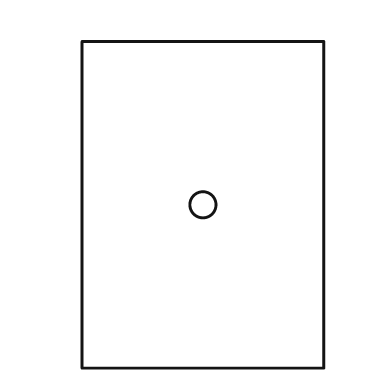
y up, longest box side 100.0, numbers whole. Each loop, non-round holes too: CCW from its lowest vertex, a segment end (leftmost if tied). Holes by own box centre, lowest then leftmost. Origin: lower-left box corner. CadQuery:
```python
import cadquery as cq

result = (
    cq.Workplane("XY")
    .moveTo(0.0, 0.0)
    .lineTo(74.0, 0.0)
    .lineTo(74.0, 100.0)
    .lineTo(0.0, 100.0)
    .close()
    .moveTo(37.0, 50.0)
    .circle(4.0)
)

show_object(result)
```